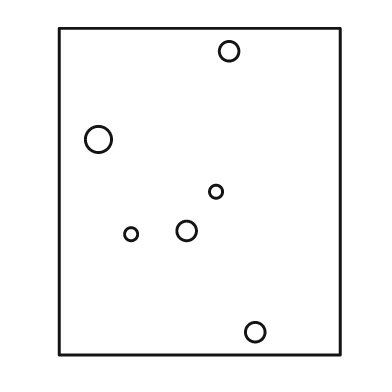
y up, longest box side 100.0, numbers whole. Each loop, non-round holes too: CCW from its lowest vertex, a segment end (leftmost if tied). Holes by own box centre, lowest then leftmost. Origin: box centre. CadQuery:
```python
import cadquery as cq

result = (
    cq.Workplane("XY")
    .moveTo(-43.0, -50.0)
    .lineTo(43.0, -50.0)
    .lineTo(43.0, 50.0)
    .lineTo(-43.0, 50.0)
    .close()
    .moveTo(17.0, -43.0)
    .circle(3.0)
    .moveTo(-21.0, -13.0)
    .circle(2.0)
    .moveTo(-4.0, -12.0)
    .circle(3.0)
    .moveTo(5.0, 0.0)
    .circle(2.0)
    .moveTo(-31.0, 16.0)
    .circle(4.0)
    .moveTo(9.0, 43.0)
    .circle(3.0)
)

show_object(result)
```